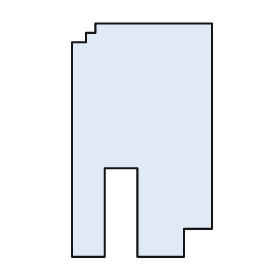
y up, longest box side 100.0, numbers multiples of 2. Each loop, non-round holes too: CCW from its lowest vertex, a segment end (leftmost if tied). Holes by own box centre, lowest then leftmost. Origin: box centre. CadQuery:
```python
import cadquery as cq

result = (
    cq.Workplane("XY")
    .moveTo(-30.0, -50.0)
    .lineTo(-16.0, -50.0)
    .lineTo(-16.0, -12.0)
    .lineTo(-2.0, -12.0)
    .lineTo(-2.0, -50.0)
    .lineTo(18.0, -50.0)
    .lineTo(18.0, -38.0)
    .lineTo(30.0, -38.0)
    .lineTo(30.0, 50.0)
    .lineTo(-20.0, 50.0)
    .lineTo(-20.0, 46.0)
    .lineTo(-24.0, 46.0)
    .lineTo(-24.0, 42.0)
    .lineTo(-30.0, 42.0)
    .close()
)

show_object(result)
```